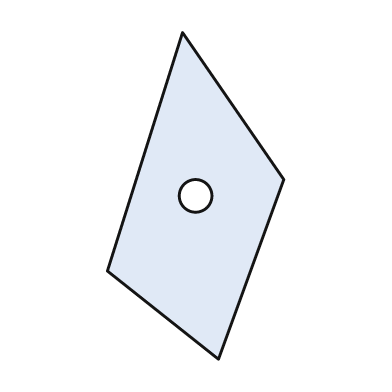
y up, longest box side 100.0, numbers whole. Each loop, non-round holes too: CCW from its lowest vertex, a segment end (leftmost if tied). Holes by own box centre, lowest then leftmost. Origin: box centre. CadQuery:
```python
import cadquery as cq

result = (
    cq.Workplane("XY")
    .moveTo(7.0, -50.0)
    .lineTo(27.0, 5.0)
    .lineTo(-4.0, 50.0)
    .lineTo(-27.0, -23.0)
    .close()
    .moveTo(0.0, 0.0)
    .circle(5.0)
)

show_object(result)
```